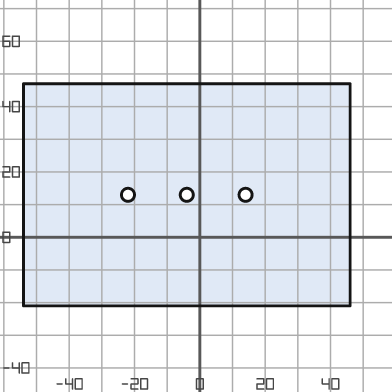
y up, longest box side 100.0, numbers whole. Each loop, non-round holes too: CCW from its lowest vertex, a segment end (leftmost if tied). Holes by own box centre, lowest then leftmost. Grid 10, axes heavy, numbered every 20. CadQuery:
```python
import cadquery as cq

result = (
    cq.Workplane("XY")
    .moveTo(-54.0, -21.0)
    .lineTo(46.0, -21.0)
    .lineTo(46.0, 47.0)
    .lineTo(-54.0, 47.0)
    .close()
    .moveTo(-22.0, 13.0)
    .circle(2.0)
    .moveTo(-4.0, 13.0)
    .circle(2.0)
    .moveTo(14.0, 13.0)
    .circle(2.0)
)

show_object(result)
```